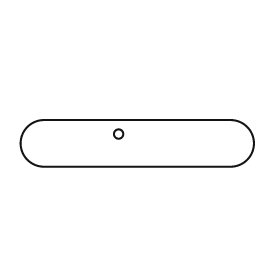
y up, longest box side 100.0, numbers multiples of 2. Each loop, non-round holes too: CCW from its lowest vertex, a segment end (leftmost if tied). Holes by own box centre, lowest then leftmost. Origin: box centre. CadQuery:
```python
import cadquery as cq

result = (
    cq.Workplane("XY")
    .moveTo(-40.0, -10.0)
    .lineTo(40.0, -10.0)
    .threePointArc((50.0, 0.0), (40.0, 10.0))
    .lineTo(-40.0, 10.0)
    .threePointArc((-50.0, 0.0), (-40.0, -10.0))
    .close()
    .moveTo(-8.0, 4.0)
    .circle(2.0)
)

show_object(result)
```